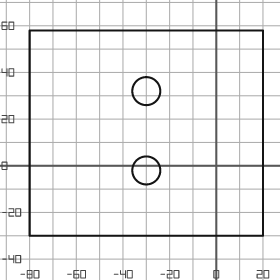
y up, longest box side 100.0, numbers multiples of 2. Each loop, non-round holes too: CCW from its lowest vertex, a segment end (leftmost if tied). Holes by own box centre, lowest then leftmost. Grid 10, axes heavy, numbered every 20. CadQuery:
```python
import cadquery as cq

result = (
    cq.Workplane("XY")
    .moveTo(-80.0, -30.0)
    .lineTo(20.0, -30.0)
    .lineTo(20.0, 58.0)
    .lineTo(-80.0, 58.0)
    .close()
    .moveTo(-30.0, -2.0)
    .circle(6.0)
    .moveTo(-30.0, 32.0)
    .circle(6.0)
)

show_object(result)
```